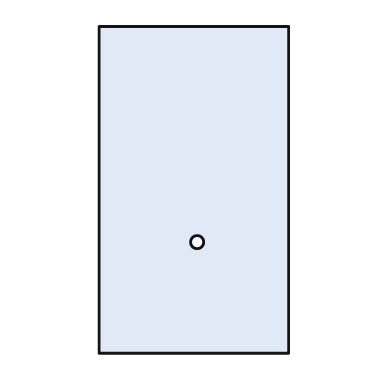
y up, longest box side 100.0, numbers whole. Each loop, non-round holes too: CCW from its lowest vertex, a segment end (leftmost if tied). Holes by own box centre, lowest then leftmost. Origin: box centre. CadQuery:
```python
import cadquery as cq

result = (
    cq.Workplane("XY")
    .moveTo(-29.0, -50.0)
    .lineTo(29.0, -50.0)
    .lineTo(29.0, 50.0)
    .lineTo(-29.0, 50.0)
    .close()
    .moveTo(1.0, -16.0)
    .circle(2.0)
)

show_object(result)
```